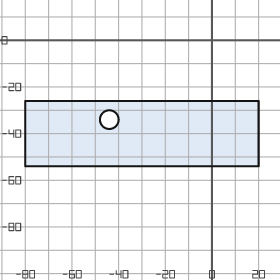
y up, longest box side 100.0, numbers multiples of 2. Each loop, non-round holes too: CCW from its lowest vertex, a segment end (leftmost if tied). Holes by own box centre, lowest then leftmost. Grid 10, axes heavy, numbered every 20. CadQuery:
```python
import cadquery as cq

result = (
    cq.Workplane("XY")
    .moveTo(-80.0, -54.0)
    .lineTo(20.0, -54.0)
    .lineTo(20.0, -26.0)
    .lineTo(-80.0, -26.0)
    .close()
    .moveTo(-44.0, -34.0)
    .circle(4.0)
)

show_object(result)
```